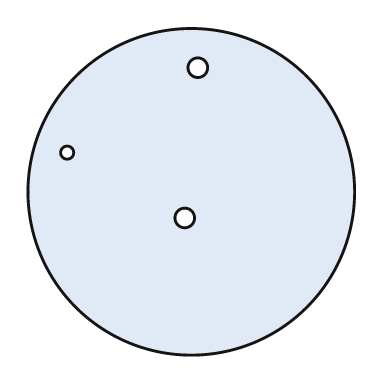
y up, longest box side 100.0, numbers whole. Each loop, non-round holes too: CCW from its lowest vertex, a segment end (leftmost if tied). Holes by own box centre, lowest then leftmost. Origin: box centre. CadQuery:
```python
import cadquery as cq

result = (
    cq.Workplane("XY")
    .moveTo(0.0, 0.0)
    .circle(50.0)
    .moveTo(-2.0, -8.0)
    .circle(3.0)
    .moveTo(-38.0, 12.0)
    .circle(2.0)
    .moveTo(2.0, 38.0)
    .circle(3.0)
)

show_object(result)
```